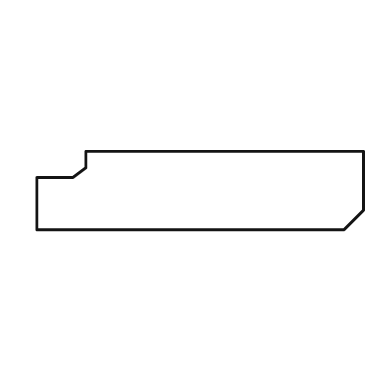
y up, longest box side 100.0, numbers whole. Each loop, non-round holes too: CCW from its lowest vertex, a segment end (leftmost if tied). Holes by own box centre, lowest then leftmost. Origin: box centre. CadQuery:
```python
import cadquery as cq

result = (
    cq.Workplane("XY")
    .moveTo(-50.0, -12.0)
    .lineTo(44.0, -12.0)
    .lineTo(50.0, -6.0)
    .lineTo(50.0, 12.0)
    .lineTo(-35.0, 12.0)
    .lineTo(-35.0, 7.0)
    .lineTo(-39.0, 4.0)
    .lineTo(-50.0, 4.0)
    .close()
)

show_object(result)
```